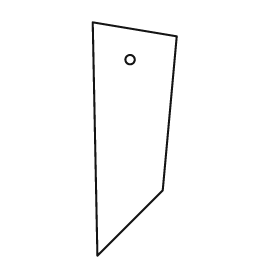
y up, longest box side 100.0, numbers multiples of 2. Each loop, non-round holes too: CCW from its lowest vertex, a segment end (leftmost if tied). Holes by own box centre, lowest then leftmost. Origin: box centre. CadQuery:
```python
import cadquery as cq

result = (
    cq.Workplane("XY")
    .moveTo(-16.0, -50.0)
    .lineTo(12.0, -22.0)
    .lineTo(18.0, 44.0)
    .lineTo(-18.0, 50.0)
    .close()
    .moveTo(-2.0, 34.0)
    .circle(2.0)
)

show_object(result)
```